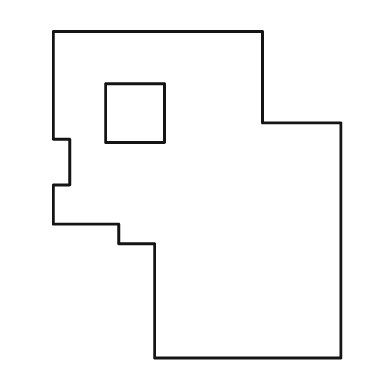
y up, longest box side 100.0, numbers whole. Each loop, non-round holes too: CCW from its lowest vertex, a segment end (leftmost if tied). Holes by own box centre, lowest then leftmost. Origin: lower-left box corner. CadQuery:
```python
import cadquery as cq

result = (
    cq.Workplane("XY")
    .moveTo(31.0, 0.0)
    .lineTo(88.0, 0.0)
    .lineTo(88.0, 72.0)
    .lineTo(64.0, 72.0)
    .lineTo(64.0, 100.0)
    .lineTo(0.0, 100.0)
    .lineTo(0.0, 67.0)
    .lineTo(5.0, 67.0)
    .lineTo(5.0, 53.0)
    .lineTo(0.0, 53.0)
    .lineTo(0.0, 41.0)
    .lineTo(20.0, 41.0)
    .lineTo(20.0, 35.0)
    .lineTo(31.0, 35.0)
    .close()
    .moveTo(16.0, 66.0)
    .lineTo(34.0, 66.0)
    .lineTo(34.0, 84.0)
    .lineTo(16.0, 84.0)
    .close()
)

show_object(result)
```